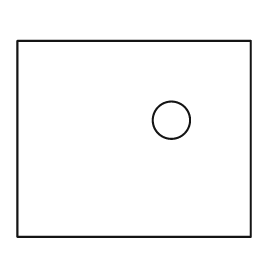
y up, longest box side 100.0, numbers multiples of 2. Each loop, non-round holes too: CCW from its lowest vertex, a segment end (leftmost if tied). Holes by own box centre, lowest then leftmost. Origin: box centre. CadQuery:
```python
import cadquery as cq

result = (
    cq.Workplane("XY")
    .moveTo(-50.0, -42.0)
    .lineTo(50.0, -42.0)
    .lineTo(50.0, 42.0)
    .lineTo(-50.0, 42.0)
    .close()
    .moveTo(16.0, 8.0)
    .circle(8.0)
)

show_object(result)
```